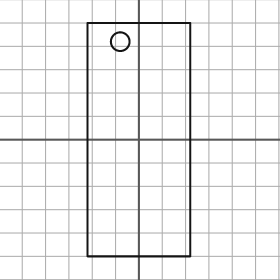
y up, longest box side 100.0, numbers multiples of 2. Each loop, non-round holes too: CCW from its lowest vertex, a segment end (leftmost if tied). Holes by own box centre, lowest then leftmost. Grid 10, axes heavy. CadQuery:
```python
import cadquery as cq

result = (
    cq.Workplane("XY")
    .moveTo(-22.0, -50.0)
    .lineTo(22.0, -50.0)
    .lineTo(22.0, 50.0)
    .lineTo(-22.0, 50.0)
    .close()
    .moveTo(-8.0, 42.0)
    .circle(4.0)
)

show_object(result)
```